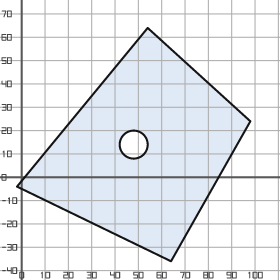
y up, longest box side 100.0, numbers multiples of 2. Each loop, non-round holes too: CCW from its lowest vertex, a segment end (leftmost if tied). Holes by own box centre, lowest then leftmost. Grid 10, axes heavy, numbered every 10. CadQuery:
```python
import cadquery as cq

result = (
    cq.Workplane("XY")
    .moveTo(64.0, -36.0)
    .lineTo(98.0, 24.0)
    .lineTo(54.0, 64.0)
    .lineTo(-2.0, -4.0)
    .close()
    .moveTo(48.0, 14.0)
    .circle(6.0)
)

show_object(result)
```